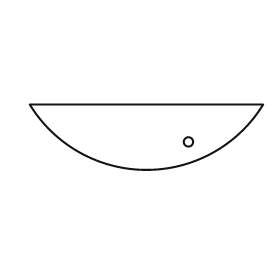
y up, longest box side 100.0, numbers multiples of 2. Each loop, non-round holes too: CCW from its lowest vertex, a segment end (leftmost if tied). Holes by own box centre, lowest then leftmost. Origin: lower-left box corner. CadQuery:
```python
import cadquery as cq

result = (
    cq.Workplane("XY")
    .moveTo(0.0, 28.0)
    .threePointArc((50.0, 0.0), (100.0, 28.0))
    .close()
    .moveTo(68.0, 12.0)
    .circle(2.0)
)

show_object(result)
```